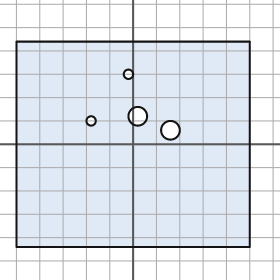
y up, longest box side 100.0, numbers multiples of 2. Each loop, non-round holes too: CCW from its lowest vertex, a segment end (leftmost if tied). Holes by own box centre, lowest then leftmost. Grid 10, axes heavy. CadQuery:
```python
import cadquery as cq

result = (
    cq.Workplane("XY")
    .moveTo(-50.0, -44.0)
    .lineTo(50.0, -44.0)
    .lineTo(50.0, 44.0)
    .lineTo(-50.0, 44.0)
    .close()
    .moveTo(16.0, 6.0)
    .circle(4.0)
    .moveTo(-18.0, 10.0)
    .circle(2.0)
    .moveTo(2.0, 12.0)
    .circle(4.0)
    .moveTo(-2.0, 30.0)
    .circle(2.0)
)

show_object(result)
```